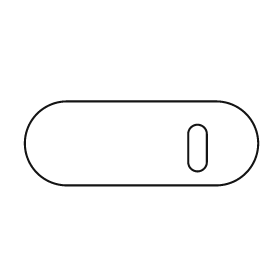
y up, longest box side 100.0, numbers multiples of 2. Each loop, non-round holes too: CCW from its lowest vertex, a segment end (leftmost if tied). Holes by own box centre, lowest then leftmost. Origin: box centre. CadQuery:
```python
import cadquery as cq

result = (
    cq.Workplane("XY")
    .moveTo(-32.0, -18.0)
    .lineTo(32.0, -18.0)
    .threePointArc((50.0, 0.0), (32.0, 18.0))
    .lineTo(-32.0, 18.0)
    .threePointArc((-50.0, 0.0), (-32.0, -18.0))
    .close()
    .moveTo(20.0, -8.0)
    .threePointArc((24.0, -12.0), (28.0, -8.0))
    .lineTo(28.0, 4.0)
    .threePointArc((24.0, 8.0), (20.0, 4.0))
    .close()
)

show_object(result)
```